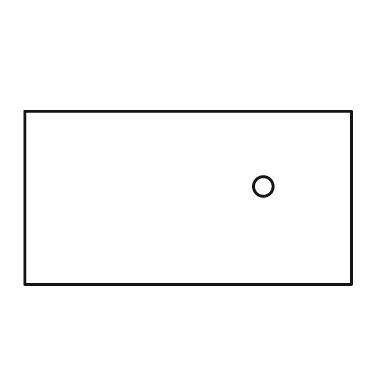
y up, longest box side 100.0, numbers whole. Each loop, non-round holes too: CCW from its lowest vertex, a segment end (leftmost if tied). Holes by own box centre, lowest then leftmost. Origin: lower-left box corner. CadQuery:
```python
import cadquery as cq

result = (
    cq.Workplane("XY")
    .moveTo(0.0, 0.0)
    .lineTo(100.0, 0.0)
    .lineTo(100.0, 53.0)
    .lineTo(0.0, 53.0)
    .close()
    .moveTo(73.0, 30.0)
    .circle(3.0)
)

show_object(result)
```